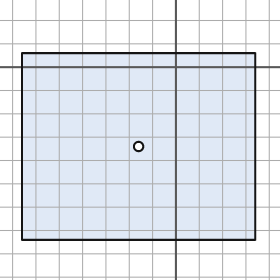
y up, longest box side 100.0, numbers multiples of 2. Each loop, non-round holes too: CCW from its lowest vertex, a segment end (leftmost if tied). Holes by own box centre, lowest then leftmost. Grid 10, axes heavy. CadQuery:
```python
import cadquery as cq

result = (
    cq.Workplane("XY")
    .moveTo(-66.0, -74.0)
    .lineTo(34.0, -74.0)
    .lineTo(34.0, 6.0)
    .lineTo(-66.0, 6.0)
    .close()
    .moveTo(-16.0, -34.0)
    .circle(2.0)
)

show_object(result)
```